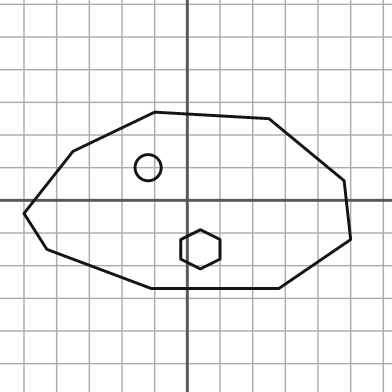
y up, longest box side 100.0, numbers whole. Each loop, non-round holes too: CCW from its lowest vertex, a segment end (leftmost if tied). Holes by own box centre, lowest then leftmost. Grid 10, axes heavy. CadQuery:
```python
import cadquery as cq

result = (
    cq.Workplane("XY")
    .moveTo(-11.0, -27.0)
    .lineTo(28.0, -27.0)
    .lineTo(50.0, -12.0)
    .lineTo(48.0, 6.0)
    .lineTo(25.0, 25.0)
    .lineTo(-10.0, 27.0)
    .lineTo(-35.0, 15.0)
    .lineTo(-50.0, -4.0)
    .lineTo(-43.0, -15.0)
    .close()
    .moveTo(4.0, -21.0)
    .lineTo(10.0, -18.0)
    .lineTo(10.0, -12.0)
    .lineTo(4.0, -9.0)
    .lineTo(-2.0, -12.0)
    .lineTo(-2.0, -18.0)
    .close()
    .moveTo(-12.0, 10.0)
    .circle(4.0)
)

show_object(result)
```